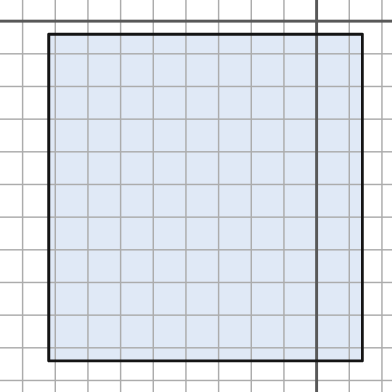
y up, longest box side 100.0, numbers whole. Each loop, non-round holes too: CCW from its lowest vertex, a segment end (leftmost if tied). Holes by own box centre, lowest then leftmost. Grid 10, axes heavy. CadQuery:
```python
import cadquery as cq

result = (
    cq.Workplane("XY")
    .moveTo(-82.0, -104.0)
    .lineTo(14.0, -104.0)
    .lineTo(14.0, -4.0)
    .lineTo(-82.0, -4.0)
    .close()
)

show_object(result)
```